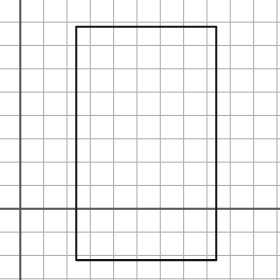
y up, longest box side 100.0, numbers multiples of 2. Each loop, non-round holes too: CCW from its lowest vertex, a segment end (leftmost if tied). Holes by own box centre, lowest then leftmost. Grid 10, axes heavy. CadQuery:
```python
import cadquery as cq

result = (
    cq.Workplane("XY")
    .moveTo(24.0, -22.0)
    .lineTo(84.0, -22.0)
    .lineTo(84.0, 78.0)
    .lineTo(24.0, 78.0)
    .close()
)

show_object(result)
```